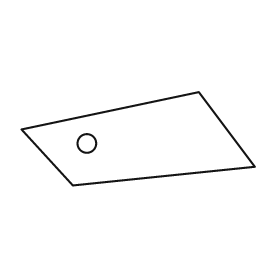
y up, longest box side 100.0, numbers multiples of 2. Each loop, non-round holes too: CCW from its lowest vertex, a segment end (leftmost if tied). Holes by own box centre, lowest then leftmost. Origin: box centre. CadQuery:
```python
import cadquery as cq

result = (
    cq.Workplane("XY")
    .moveTo(-28.0, -20.0)
    .lineTo(50.0, -12.0)
    .lineTo(26.0, 20.0)
    .lineTo(-50.0, 4.0)
    .close()
    .moveTo(-22.0, -2.0)
    .circle(4.0)
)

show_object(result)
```